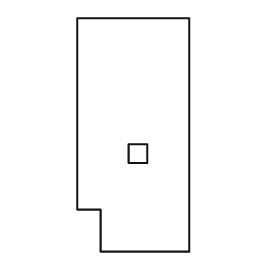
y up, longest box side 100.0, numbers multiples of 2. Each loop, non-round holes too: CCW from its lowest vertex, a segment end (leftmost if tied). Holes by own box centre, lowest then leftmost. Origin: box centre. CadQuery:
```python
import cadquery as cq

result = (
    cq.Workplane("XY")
    .moveTo(-14.0, -50.0)
    .lineTo(24.0, -50.0)
    .lineTo(24.0, 50.0)
    .lineTo(-24.0, 50.0)
    .lineTo(-24.0, -32.0)
    .lineTo(-14.0, -32.0)
    .close()
    .moveTo(-2.0, -12.0)
    .lineTo(6.0, -12.0)
    .lineTo(6.0, -4.0)
    .lineTo(-2.0, -4.0)
    .close()
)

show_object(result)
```